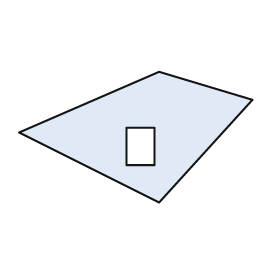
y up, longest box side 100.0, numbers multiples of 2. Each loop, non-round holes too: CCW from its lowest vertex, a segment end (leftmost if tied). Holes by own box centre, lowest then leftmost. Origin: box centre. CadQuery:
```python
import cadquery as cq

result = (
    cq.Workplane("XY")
    .moveTo(10.0, -28.0)
    .lineTo(50.0, 16.0)
    .lineTo(10.0, 28.0)
    .lineTo(-50.0, 2.0)
    .close()
    .moveTo(-4.0, -12.0)
    .lineTo(8.0, -12.0)
    .lineTo(8.0, 4.0)
    .lineTo(-4.0, 4.0)
    .close()
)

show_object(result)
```